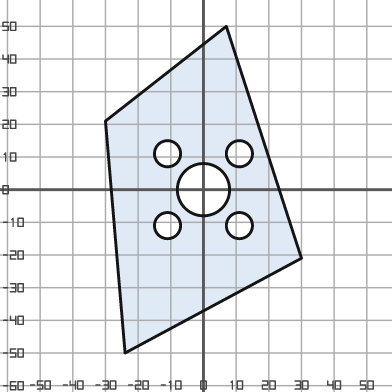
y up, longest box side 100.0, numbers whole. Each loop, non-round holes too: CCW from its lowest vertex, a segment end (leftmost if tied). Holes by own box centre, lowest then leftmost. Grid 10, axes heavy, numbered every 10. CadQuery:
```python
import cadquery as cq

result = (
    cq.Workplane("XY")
    .moveTo(-24.0, -50.0)
    .lineTo(30.0, -21.0)
    .lineTo(7.0, 50.0)
    .lineTo(-30.0, 21.0)
    .close()
    .moveTo(-11.0, -11.0)
    .circle(4.0)
    .moveTo(11.0, -11.0)
    .circle(4.0)
    .moveTo(0.0, 0.0)
    .circle(8.0)
    .moveTo(-11.0, 11.0)
    .circle(4.0)
    .moveTo(11.0, 11.0)
    .circle(4.0)
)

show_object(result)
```